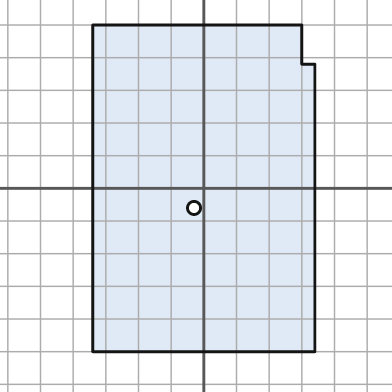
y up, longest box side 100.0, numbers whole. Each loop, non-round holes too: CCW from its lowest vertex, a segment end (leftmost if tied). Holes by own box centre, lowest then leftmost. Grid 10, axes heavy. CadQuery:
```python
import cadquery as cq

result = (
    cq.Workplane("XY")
    .moveTo(-34.0, -50.0)
    .lineTo(34.0, -50.0)
    .lineTo(34.0, 38.0)
    .lineTo(30.0, 38.0)
    .lineTo(30.0, 50.0)
    .lineTo(-34.0, 50.0)
    .close()
    .moveTo(-3.0, -6.0)
    .circle(2.0)
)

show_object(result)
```